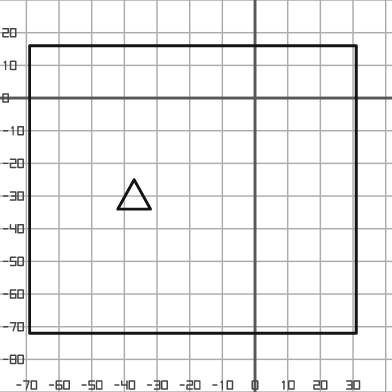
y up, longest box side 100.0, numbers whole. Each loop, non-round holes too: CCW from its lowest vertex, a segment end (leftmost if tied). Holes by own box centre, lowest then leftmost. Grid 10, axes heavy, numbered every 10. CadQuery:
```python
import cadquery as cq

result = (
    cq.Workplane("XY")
    .moveTo(-69.0, -72.0)
    .lineTo(31.0, -72.0)
    .lineTo(31.0, 16.0)
    .lineTo(-69.0, 16.0)
    .close()
    .moveTo(-42.0, -34.0)
    .lineTo(-32.0, -34.0)
    .lineTo(-37.0, -25.0)
    .close()
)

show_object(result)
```